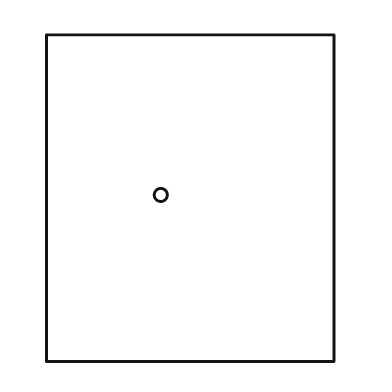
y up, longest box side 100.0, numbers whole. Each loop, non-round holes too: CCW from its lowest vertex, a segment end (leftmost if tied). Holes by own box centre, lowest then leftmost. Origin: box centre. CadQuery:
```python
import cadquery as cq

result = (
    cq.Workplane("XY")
    .moveTo(-44.0, -50.0)
    .lineTo(44.0, -50.0)
    .lineTo(44.0, 50.0)
    .lineTo(-44.0, 50.0)
    .close()
    .moveTo(-9.0, 1.0)
    .circle(2.0)
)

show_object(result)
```